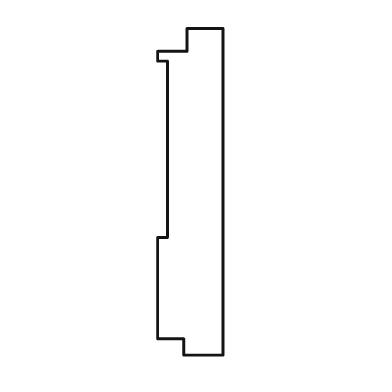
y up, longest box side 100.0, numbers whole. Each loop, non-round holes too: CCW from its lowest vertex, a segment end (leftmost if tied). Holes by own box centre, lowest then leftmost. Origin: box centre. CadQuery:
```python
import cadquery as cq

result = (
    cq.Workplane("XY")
    .moveTo(-2.0, -50.0)
    .lineTo(10.0, -50.0)
    .lineTo(10.0, 50.0)
    .lineTo(-1.0, 50.0)
    .lineTo(-1.0, 43.0)
    .lineTo(-10.0, 43.0)
    .lineTo(-10.0, 40.0)
    .lineTo(-7.0, 40.0)
    .lineTo(-7.0, -14.0)
    .lineTo(-10.0, -14.0)
    .lineTo(-10.0, -45.0)
    .lineTo(-2.0, -45.0)
    .close()
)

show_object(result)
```